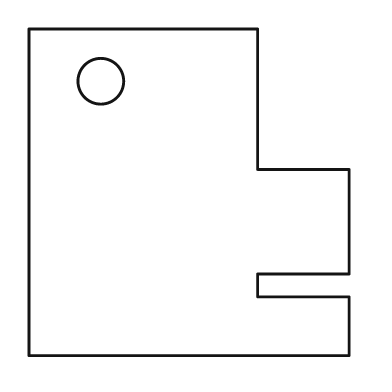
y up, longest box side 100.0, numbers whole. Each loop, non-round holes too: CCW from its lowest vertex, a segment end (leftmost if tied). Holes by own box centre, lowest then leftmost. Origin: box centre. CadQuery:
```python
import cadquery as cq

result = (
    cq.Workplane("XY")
    .moveTo(-49.0, -50.0)
    .lineTo(49.0, -50.0)
    .lineTo(49.0, -32.0)
    .lineTo(21.0, -32.0)
    .lineTo(21.0, -25.0)
    .lineTo(49.0, -25.0)
    .lineTo(49.0, 7.0)
    .lineTo(21.0, 7.0)
    .lineTo(21.0, 50.0)
    .lineTo(-49.0, 50.0)
    .close()
    .moveTo(-27.0, 34.0)
    .circle(7.0)
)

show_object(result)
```